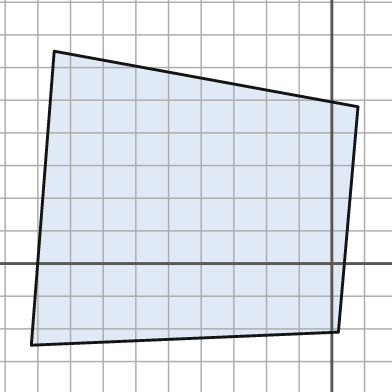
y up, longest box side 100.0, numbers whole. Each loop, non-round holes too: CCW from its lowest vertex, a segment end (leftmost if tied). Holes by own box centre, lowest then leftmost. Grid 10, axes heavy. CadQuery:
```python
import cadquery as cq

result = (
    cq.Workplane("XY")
    .moveTo(-92.0, -25.0)
    .lineTo(2.0, -21.0)
    .lineTo(8.0, 48.0)
    .lineTo(-85.0, 65.0)
    .close()
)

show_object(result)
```